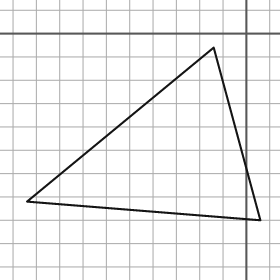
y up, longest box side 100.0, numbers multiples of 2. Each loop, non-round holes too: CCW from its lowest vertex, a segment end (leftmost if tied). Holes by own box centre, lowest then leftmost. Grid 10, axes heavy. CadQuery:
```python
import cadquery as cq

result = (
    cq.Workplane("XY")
    .moveTo(6.0, -80.0)
    .lineTo(-14.0, -6.0)
    .lineTo(-94.0, -72.0)
    .close()
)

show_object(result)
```